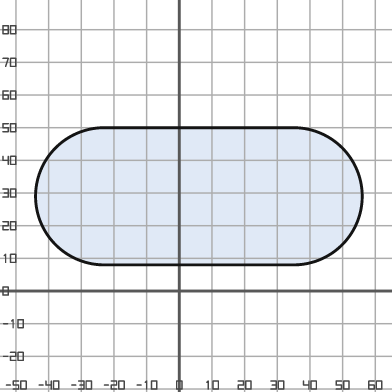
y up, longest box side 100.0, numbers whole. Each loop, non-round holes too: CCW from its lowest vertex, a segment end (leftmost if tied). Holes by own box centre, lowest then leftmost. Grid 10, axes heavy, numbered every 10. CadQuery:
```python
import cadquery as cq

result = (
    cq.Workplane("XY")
    .moveTo(-23.0, 8.0)
    .lineTo(35.0, 8.0)
    .threePointArc((56.0, 29.0), (35.0, 50.0))
    .lineTo(-23.0, 50.0)
    .threePointArc((-44.0, 29.0), (-23.0, 8.0))
    .close()
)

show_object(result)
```